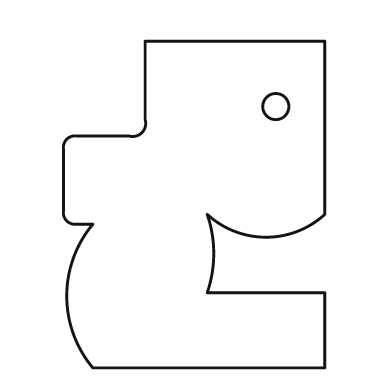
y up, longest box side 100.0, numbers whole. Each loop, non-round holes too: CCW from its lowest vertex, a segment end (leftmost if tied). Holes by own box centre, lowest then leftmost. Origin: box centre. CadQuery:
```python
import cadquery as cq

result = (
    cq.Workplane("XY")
    .moveTo(-31.0, -50.0)
    .lineTo(40.0, -50.0)
    .lineTo(40.0, -27.0)
    .lineTo(4.0, -27.0)
    .threePointArc((6.0, -15.0), (4.0, -3.0))
    .threePointArc((22.0, -10.0), (40.0, -3.0))
    .lineTo(40.0, 50.0)
    .lineTo(-15.0, 50.0)
    .lineTo(-15.0, 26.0)
    .threePointArc((-16.0, 22.0), (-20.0, 21.0))
    .lineTo(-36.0, 21.0)
    .threePointArc((-39.0, 20.0), (-40.0, 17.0))
    .lineTo(-40.0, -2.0)
    .threePointArc((-39.0, -5.0), (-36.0, -6.0))
    .lineTo(-31.0, -6.0)
    .threePointArc((-39.0, -28.0), (-31.0, -50.0))
    .close()
    .moveTo(25.0, 30.0)
    .circle(4.0)
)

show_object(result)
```